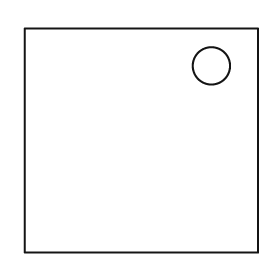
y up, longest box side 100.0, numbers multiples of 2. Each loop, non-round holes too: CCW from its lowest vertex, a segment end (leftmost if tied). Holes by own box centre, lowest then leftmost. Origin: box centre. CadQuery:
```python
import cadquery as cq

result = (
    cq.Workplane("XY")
    .moveTo(-50.0, -48.0)
    .lineTo(50.0, -48.0)
    .lineTo(50.0, 48.0)
    .lineTo(-50.0, 48.0)
    .close()
    .moveTo(30.0, 32.0)
    .circle(8.0)
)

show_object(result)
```